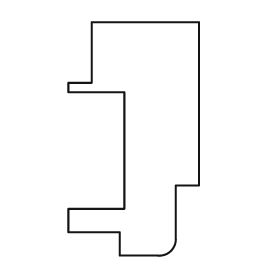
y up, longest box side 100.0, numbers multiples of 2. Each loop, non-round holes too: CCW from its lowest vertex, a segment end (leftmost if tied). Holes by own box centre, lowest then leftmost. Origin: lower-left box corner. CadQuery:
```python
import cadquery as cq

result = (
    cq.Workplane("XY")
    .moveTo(22.0, 0.0)
    .lineTo(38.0, 0.0)
    .threePointArc((44.0, 2.0), (46.0, 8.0))
    .lineTo(46.0, 30.0)
    .lineTo(56.0, 30.0)
    .lineTo(56.0, 100.0)
    .lineTo(10.0, 100.0)
    .lineTo(10.0, 74.0)
    .lineTo(0.0, 74.0)
    .lineTo(0.0, 70.0)
    .lineTo(24.0, 70.0)
    .lineTo(24.0, 20.0)
    .lineTo(0.0, 20.0)
    .lineTo(0.0, 10.0)
    .lineTo(22.0, 10.0)
    .close()
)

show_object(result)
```